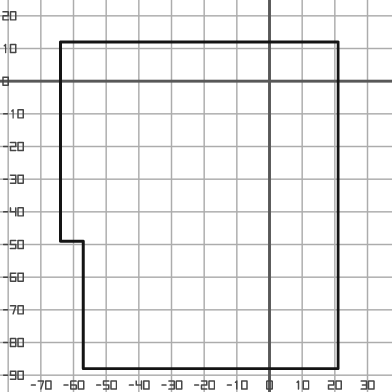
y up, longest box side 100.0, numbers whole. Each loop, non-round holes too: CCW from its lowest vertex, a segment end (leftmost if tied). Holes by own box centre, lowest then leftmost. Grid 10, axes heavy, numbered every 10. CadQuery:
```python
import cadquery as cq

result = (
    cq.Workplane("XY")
    .moveTo(-57.0, -88.0)
    .lineTo(21.0, -88.0)
    .lineTo(21.0, 12.0)
    .lineTo(-64.0, 12.0)
    .lineTo(-64.0, -49.0)
    .lineTo(-57.0, -49.0)
    .close()
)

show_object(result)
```